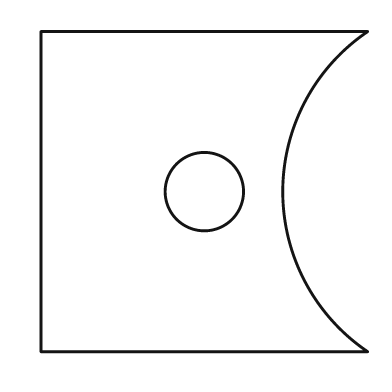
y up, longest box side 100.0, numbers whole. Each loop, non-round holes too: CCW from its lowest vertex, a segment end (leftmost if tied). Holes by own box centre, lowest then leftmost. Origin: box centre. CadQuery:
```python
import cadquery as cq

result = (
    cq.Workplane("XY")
    .moveTo(-50.0, -49.0)
    .lineTo(50.0, -49.0)
    .threePointArc((24.0, 0.0), (50.0, 49.0))
    .lineTo(-50.0, 49.0)
    .close()
    .moveTo(0.0, 0.0)
    .circle(12.0)
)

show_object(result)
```